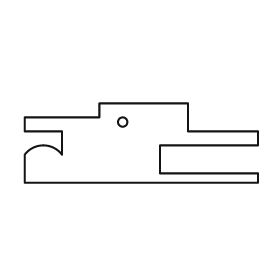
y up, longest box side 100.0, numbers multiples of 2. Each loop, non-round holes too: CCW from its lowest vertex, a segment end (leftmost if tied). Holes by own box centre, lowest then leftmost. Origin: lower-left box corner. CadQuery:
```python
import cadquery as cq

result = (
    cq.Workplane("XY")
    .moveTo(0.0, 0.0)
    .lineTo(100.0, 0.0)
    .lineTo(100.0, 4.0)
    .lineTo(58.0, 4.0)
    .lineTo(58.0, 16.0)
    .lineTo(100.0, 16.0)
    .lineTo(100.0, 22.0)
    .lineTo(70.0, 22.0)
    .lineTo(70.0, 34.0)
    .lineTo(32.0, 34.0)
    .lineTo(32.0, 28.0)
    .lineTo(0.0, 28.0)
    .lineTo(0.0, 22.0)
    .lineTo(16.0, 22.0)
    .lineTo(16.0, 12.0)
    .threePointArc((8.0, 16.0), (0.0, 12.0))
    .close()
    .moveTo(42.0, 26.0)
    .circle(2.0)
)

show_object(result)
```